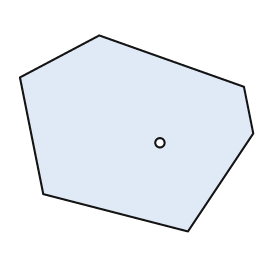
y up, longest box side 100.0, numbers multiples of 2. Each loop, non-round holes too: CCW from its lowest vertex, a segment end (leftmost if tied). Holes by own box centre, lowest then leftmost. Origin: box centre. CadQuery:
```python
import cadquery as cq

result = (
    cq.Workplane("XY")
    .moveTo(22.0, -42.0)
    .lineTo(50.0, 0.0)
    .lineTo(46.0, 20.0)
    .lineTo(-16.0, 42.0)
    .lineTo(-50.0, 24.0)
    .lineTo(-40.0, -26.0)
    .close()
    .moveTo(10.0, -4.0)
    .circle(2.0)
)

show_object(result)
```